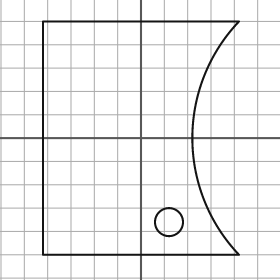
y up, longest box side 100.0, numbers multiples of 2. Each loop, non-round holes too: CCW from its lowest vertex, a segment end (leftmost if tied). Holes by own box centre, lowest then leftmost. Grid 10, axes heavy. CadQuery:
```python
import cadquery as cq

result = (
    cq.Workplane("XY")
    .moveTo(-42.0, -50.0)
    .lineTo(42.0, -50.0)
    .threePointArc((22.0, 0.0), (42.0, 50.0))
    .lineTo(-42.0, 50.0)
    .close()
    .moveTo(12.0, -36.0)
    .circle(6.0)
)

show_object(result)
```